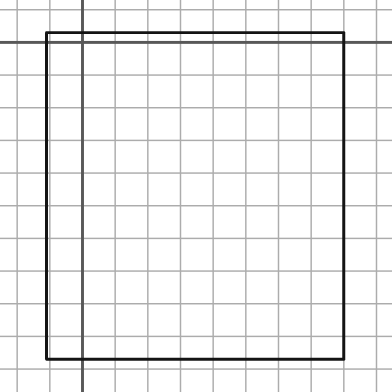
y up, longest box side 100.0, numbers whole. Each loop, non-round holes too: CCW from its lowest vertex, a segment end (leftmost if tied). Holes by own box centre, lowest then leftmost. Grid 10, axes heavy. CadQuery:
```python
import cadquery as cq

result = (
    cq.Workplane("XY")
    .moveTo(-11.0, -97.0)
    .lineTo(80.0, -97.0)
    .lineTo(80.0, 3.0)
    .lineTo(-11.0, 3.0)
    .close()
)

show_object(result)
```